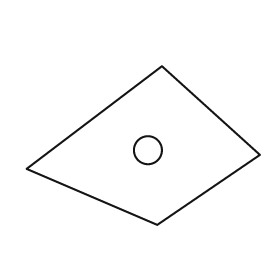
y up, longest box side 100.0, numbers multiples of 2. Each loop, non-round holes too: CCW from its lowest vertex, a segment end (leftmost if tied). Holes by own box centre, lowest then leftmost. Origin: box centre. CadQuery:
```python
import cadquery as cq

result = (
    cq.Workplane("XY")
    .moveTo(6.0, -34.0)
    .lineTo(50.0, -4.0)
    .lineTo(8.0, 34.0)
    .lineTo(-50.0, -10.0)
    .close()
    .moveTo(2.0, -2.0)
    .circle(6.0)
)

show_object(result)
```